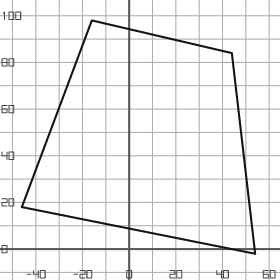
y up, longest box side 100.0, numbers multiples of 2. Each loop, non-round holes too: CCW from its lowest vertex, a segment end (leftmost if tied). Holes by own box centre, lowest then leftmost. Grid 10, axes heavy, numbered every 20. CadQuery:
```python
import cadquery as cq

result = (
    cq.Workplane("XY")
    .moveTo(54.0, -2.0)
    .lineTo(44.0, 84.0)
    .lineTo(-16.0, 98.0)
    .lineTo(-46.0, 18.0)
    .close()
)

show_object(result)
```